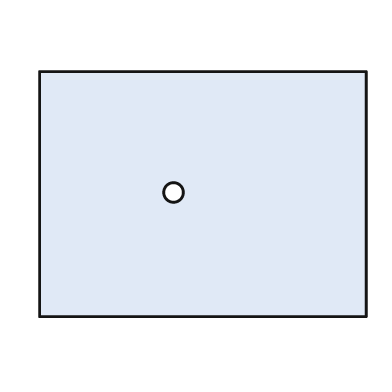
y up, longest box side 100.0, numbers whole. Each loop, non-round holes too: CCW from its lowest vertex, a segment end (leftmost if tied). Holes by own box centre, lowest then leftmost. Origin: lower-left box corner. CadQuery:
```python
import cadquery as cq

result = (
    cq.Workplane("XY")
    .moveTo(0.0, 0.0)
    .lineTo(100.0, 0.0)
    .lineTo(100.0, 75.0)
    .lineTo(0.0, 75.0)
    .close()
    .moveTo(41.0, 38.0)
    .circle(3.0)
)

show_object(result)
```